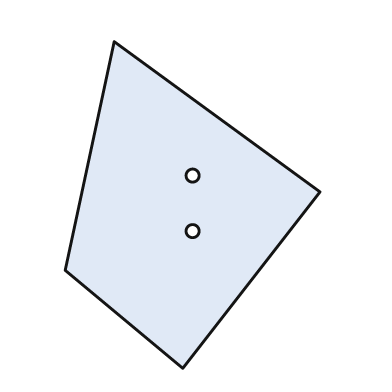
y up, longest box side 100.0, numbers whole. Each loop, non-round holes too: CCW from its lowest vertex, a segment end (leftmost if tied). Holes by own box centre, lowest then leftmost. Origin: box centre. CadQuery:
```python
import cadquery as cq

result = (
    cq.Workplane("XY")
    .moveTo(-3.0, -50.0)
    .lineTo(39.0, 4.0)
    .lineTo(-24.0, 50.0)
    .lineTo(-39.0, -20.0)
    .close()
    .moveTo(0.0, -8.0)
    .circle(2.0)
    .moveTo(0.0, 9.0)
    .circle(2.0)
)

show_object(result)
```